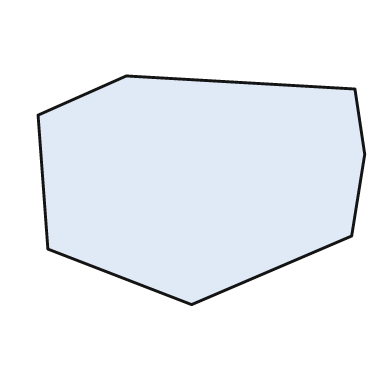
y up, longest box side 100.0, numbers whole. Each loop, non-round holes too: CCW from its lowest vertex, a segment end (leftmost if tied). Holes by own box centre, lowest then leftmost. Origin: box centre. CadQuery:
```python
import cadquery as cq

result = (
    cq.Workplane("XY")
    .moveTo(-3.0, -35.0)
    .lineTo(46.0, -14.0)
    .lineTo(50.0, 11.0)
    .lineTo(47.0, 31.0)
    .lineTo(-23.0, 35.0)
    .lineTo(-50.0, 23.0)
    .lineTo(-47.0, -18.0)
    .close()
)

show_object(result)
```